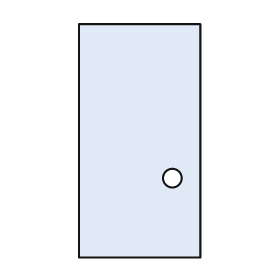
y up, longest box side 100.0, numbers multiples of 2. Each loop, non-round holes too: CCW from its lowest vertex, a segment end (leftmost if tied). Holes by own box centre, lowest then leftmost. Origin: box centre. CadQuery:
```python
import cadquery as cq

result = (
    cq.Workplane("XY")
    .moveTo(-26.0, -50.0)
    .lineTo(26.0, -50.0)
    .lineTo(26.0, 50.0)
    .lineTo(-26.0, 50.0)
    .close()
    .moveTo(14.0, -16.0)
    .circle(4.0)
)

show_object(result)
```